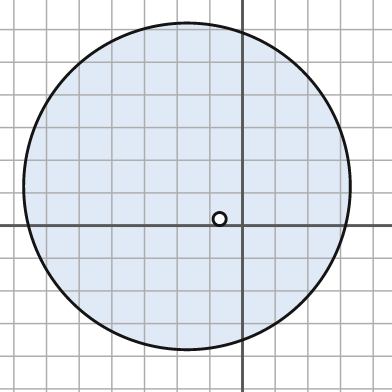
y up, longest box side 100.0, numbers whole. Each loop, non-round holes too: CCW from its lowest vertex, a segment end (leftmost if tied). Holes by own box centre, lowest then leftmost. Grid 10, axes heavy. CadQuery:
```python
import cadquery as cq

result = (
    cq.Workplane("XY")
    .moveTo(-17.0, 12.0)
    .circle(50.0)
    .moveTo(-7.0, 2.0)
    .circle(2.0)
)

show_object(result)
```